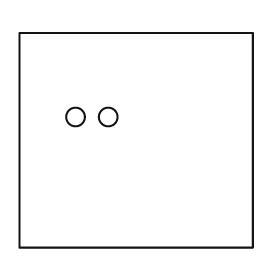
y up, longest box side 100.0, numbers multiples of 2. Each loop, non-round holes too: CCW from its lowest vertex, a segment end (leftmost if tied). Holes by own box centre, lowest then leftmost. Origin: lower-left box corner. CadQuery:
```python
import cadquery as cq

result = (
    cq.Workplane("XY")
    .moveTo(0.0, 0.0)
    .lineTo(100.0, 0.0)
    .lineTo(100.0, 92.0)
    .lineTo(0.0, 92.0)
    .close()
    .moveTo(24.0, 56.0)
    .circle(4.0)
    .moveTo(38.0, 56.0)
    .circle(4.0)
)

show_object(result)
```